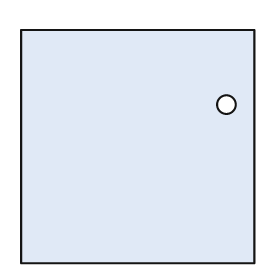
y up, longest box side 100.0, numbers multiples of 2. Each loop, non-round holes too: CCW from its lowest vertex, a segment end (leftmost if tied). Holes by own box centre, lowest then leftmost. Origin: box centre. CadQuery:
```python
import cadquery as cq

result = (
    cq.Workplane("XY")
    .moveTo(-50.0, -50.0)
    .lineTo(50.0, -50.0)
    .lineTo(50.0, 50.0)
    .lineTo(-50.0, 50.0)
    .close()
    .moveTo(38.0, 18.0)
    .circle(4.0)
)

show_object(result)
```